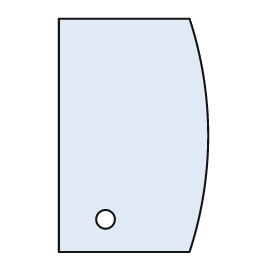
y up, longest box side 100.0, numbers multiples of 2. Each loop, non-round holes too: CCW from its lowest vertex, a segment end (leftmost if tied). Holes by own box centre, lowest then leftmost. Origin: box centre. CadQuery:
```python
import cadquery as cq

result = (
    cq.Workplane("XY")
    .moveTo(-32.0, -50.0)
    .lineTo(24.0, -50.0)
    .threePointArc((32.0, 0.0), (24.0, 50.0))
    .lineTo(-32.0, 50.0)
    .close()
    .moveTo(-12.0, -36.0)
    .circle(4.0)
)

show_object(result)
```